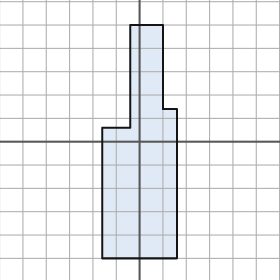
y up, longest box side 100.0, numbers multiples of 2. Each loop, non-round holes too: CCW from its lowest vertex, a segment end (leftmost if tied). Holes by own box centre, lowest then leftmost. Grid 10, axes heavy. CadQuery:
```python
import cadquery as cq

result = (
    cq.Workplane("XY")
    .moveTo(-16.0, -50.0)
    .lineTo(16.0, -50.0)
    .lineTo(16.0, 14.0)
    .lineTo(10.0, 14.0)
    .lineTo(10.0, 50.0)
    .lineTo(-4.0, 50.0)
    .lineTo(-4.0, 6.0)
    .lineTo(-16.0, 6.0)
    .close()
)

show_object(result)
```